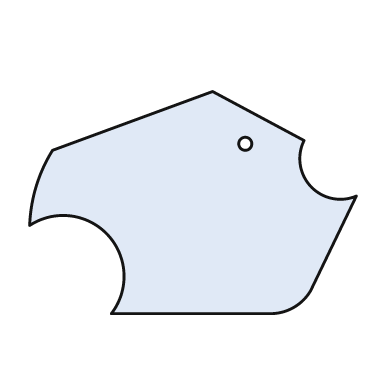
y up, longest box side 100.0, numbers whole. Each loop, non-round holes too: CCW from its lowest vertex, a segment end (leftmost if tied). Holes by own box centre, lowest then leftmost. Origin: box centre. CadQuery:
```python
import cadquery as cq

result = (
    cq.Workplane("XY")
    .moveTo(-25.0, -34.0)
    .lineTo(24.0, -34.0)
    .threePointArc((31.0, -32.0), (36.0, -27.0))
    .lineTo(50.0, 2.0)
    .threePointArc((36.0, 5.0), (34.0, 19.0))
    .lineTo(6.0, 34.0)
    .lineTo(-43.0, 16.0)
    .threePointArc((-48.0, 5.0), (-50.0, -7.0))
    .threePointArc((-26.0, -10.0), (-25.0, -34.0))
    .close()
    .moveTo(16.0, 18.0)
    .circle(2.0)
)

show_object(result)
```